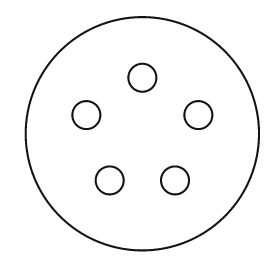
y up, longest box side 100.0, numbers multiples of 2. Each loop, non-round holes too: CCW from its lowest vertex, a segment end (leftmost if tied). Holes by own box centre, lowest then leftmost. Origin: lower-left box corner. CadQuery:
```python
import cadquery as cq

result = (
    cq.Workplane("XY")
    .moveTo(50.0, 50.0)
    .circle(50.0)
    .moveTo(36.0, 30.0)
    .circle(6.0)
    .moveTo(64.0, 30.0)
    .circle(6.0)
    .moveTo(26.0, 58.0)
    .circle(6.0)
    .moveTo(74.0, 58.0)
    .circle(6.0)
    .moveTo(50.0, 74.0)
    .circle(6.0)
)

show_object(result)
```